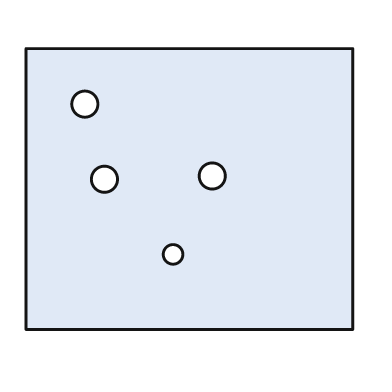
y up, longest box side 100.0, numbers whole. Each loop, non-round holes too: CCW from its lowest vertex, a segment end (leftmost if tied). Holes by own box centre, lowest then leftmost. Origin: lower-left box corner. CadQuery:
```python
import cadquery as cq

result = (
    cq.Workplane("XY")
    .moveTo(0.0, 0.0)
    .lineTo(100.0, 0.0)
    .lineTo(100.0, 86.0)
    .lineTo(0.0, 86.0)
    .close()
    .moveTo(45.0, 23.0)
    .circle(3.0)
    .moveTo(24.0, 46.0)
    .circle(4.0)
    .moveTo(57.0, 47.0)
    .circle(4.0)
    .moveTo(18.0, 69.0)
    .circle(4.0)
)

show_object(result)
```